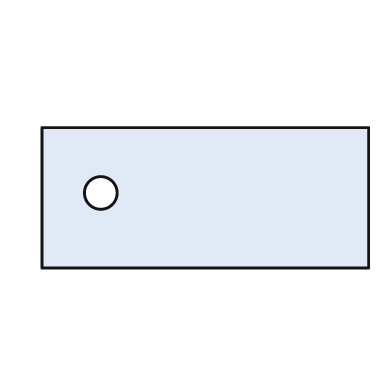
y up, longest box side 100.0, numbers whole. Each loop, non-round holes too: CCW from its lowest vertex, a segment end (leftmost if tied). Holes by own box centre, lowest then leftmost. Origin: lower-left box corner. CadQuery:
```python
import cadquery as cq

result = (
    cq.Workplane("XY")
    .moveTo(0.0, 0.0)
    .lineTo(100.0, 0.0)
    .lineTo(100.0, 43.0)
    .lineTo(0.0, 43.0)
    .close()
    .moveTo(18.0, 23.0)
    .circle(5.0)
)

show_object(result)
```